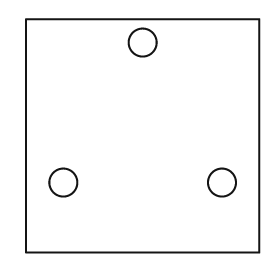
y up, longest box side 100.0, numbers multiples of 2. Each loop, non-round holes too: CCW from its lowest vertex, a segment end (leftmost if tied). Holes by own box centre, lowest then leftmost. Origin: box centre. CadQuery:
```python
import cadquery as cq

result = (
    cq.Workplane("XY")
    .moveTo(-50.0, -50.0)
    .lineTo(50.0, -50.0)
    .lineTo(50.0, 50.0)
    .lineTo(-50.0, 50.0)
    .close()
    .moveTo(-34.0, -20.0)
    .circle(6.0)
    .moveTo(34.0, -20.0)
    .circle(6.0)
    .moveTo(0.0, 40.0)
    .circle(6.0)
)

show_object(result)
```